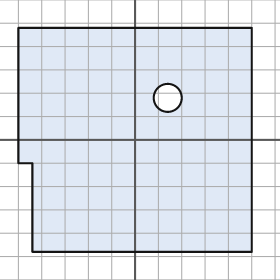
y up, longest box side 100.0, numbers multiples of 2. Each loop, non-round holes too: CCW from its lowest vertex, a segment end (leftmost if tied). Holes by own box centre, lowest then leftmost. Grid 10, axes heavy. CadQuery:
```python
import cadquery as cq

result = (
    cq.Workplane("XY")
    .moveTo(-44.0, -48.0)
    .lineTo(50.0, -48.0)
    .lineTo(50.0, 48.0)
    .lineTo(-50.0, 48.0)
    .lineTo(-50.0, -10.0)
    .lineTo(-44.0, -10.0)
    .close()
    .moveTo(14.0, 18.0)
    .circle(6.0)
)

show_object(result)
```